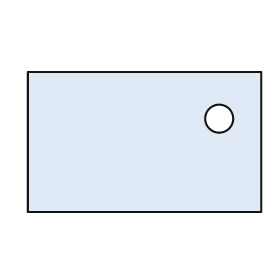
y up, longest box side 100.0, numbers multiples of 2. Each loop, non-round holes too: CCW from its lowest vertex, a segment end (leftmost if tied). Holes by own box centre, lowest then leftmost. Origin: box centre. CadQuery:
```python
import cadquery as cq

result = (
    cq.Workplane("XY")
    .moveTo(-50.0, -30.0)
    .lineTo(50.0, -30.0)
    .lineTo(50.0, 30.0)
    .lineTo(-50.0, 30.0)
    .close()
    .moveTo(32.0, 10.0)
    .circle(6.0)
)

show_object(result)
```